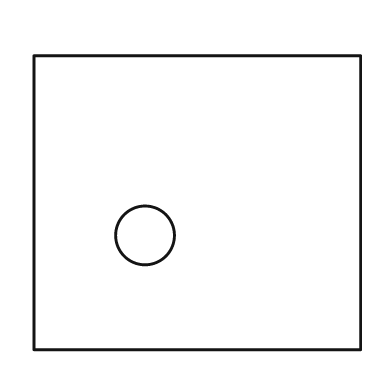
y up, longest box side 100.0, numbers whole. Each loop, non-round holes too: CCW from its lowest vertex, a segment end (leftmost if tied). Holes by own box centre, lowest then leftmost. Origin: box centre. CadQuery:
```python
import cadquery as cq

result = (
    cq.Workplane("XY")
    .moveTo(-50.0, -45.0)
    .lineTo(50.0, -45.0)
    .lineTo(50.0, 45.0)
    .lineTo(-50.0, 45.0)
    .close()
    .moveTo(-16.0, -10.0)
    .circle(9.0)
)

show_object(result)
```